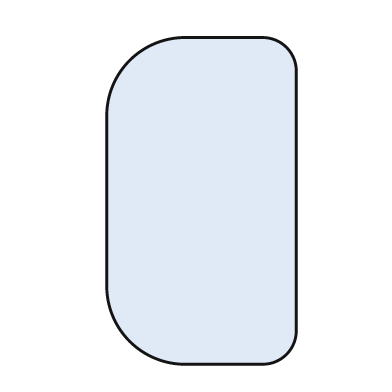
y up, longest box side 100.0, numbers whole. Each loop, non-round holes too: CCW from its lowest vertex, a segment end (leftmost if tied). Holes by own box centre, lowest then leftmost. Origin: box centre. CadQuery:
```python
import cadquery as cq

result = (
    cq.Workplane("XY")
    .moveTo(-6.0, -50.0)
    .lineTo(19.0, -50.0)
    .threePointArc((26.0, -47.0), (29.0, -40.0))
    .lineTo(29.0, 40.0)
    .threePointArc((26.0, 47.0), (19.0, 50.0))
    .lineTo(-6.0, 50.0)
    .threePointArc((-22.0, 43.0), (-29.0, 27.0))
    .lineTo(-29.0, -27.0)
    .threePointArc((-22.0, -43.0), (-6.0, -50.0))
    .close()
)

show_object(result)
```